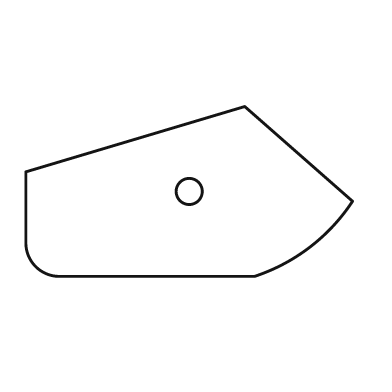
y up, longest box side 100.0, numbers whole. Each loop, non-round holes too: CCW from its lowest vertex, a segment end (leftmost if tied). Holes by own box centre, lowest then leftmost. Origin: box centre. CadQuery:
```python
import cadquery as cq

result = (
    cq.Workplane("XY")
    .moveTo(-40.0, -26.0)
    .lineTo(20.0, -26.0)
    .threePointArc((37.0, -17.0), (50.0, -3.0))
    .lineTo(17.0, 26.0)
    .lineTo(-50.0, 6.0)
    .lineTo(-50.0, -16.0)
    .threePointArc((-47.0, -23.0), (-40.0, -26.0))
    .close()
    .moveTo(0.0, 0.0)
    .circle(4.0)
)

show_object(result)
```